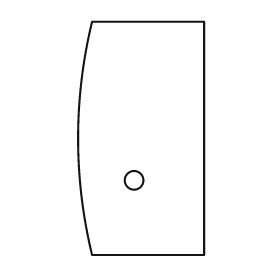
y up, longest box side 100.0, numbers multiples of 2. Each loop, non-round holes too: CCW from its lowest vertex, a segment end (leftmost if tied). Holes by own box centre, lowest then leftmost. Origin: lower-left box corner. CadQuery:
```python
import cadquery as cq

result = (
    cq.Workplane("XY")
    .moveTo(6.0, 0.0)
    .lineTo(54.0, 0.0)
    .lineTo(54.0, 100.0)
    .lineTo(6.0, 100.0)
    .threePointArc((0.0, 50.0), (6.0, 0.0))
    .close()
    .moveTo(24.0, 32.0)
    .circle(4.0)
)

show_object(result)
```